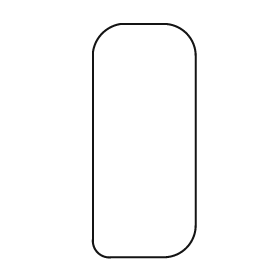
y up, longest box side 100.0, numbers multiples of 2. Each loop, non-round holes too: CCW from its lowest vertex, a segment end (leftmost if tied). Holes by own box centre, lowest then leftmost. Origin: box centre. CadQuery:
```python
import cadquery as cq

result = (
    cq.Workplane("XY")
    .moveTo(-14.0, -50.0)
    .lineTo(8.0, -50.0)
    .threePointArc((18.0, -46.0), (22.0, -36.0))
    .lineTo(22.0, 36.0)
    .threePointArc((18.0, 46.0), (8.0, 50.0))
    .lineTo(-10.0, 50.0)
    .threePointArc((-18.0, 46.0), (-22.0, 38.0))
    .lineTo(-22.0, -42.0)
    .threePointArc((-20.0, -48.0), (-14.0, -50.0))
    .close()
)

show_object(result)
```